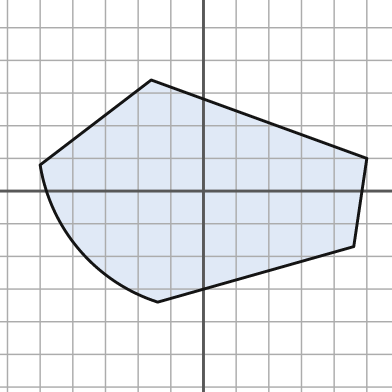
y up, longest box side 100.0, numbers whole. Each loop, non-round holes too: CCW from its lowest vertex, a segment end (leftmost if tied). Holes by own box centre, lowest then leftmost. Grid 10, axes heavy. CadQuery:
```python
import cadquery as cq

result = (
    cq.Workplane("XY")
    .moveTo(-14.0, -34.0)
    .lineTo(46.0, -17.0)
    .lineTo(50.0, 10.0)
    .lineTo(-16.0, 34.0)
    .lineTo(-50.0, 8.0)
    .threePointArc((-38.0, -18.0), (-14.0, -34.0))
    .close()
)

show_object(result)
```